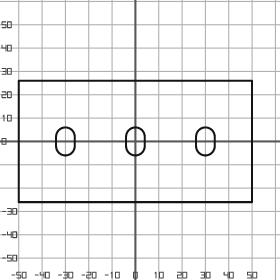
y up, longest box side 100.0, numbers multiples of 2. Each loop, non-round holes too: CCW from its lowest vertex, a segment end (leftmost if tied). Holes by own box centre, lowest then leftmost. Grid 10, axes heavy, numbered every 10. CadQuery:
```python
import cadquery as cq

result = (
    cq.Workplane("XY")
    .moveTo(-50.0, -26.0)
    .lineTo(50.0, -26.0)
    .lineTo(50.0, 26.0)
    .lineTo(-50.0, 26.0)
    .close()
    .moveTo(-34.0, -2.0)
    .threePointArc((-30.0, -6.0), (-26.0, -2.0))
    .lineTo(-26.0, 2.0)
    .threePointArc((-30.0, 6.0), (-34.0, 2.0))
    .close()
    .moveTo(-4.0, -2.0)
    .threePointArc((0.0, -6.0), (4.0, -2.0))
    .lineTo(4.0, 2.0)
    .threePointArc((0.0, 6.0), (-4.0, 2.0))
    .close()
    .moveTo(26.0, -2.0)
    .threePointArc((30.0, -6.0), (34.0, -2.0))
    .lineTo(34.0, 2.0)
    .threePointArc((30.0, 6.0), (26.0, 2.0))
    .close()
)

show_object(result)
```